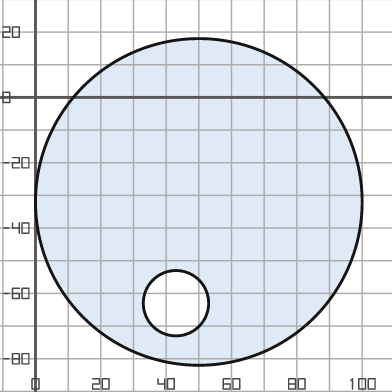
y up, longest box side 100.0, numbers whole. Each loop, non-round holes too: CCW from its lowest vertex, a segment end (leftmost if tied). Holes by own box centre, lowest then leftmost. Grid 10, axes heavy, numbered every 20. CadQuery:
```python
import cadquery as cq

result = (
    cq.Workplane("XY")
    .moveTo(50.0, -32.0)
    .circle(50.0)
    .moveTo(43.0, -63.0)
    .circle(10.0)
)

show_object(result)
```